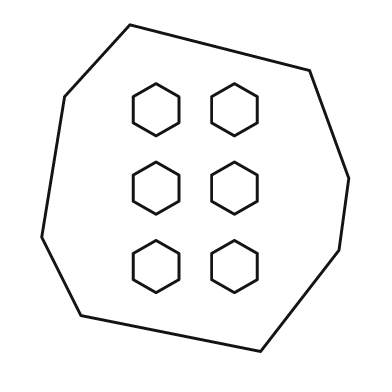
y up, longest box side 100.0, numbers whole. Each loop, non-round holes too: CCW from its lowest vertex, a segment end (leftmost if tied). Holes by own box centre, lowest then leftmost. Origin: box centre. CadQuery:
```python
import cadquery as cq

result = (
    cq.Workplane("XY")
    .moveTo(20.0, -50.0)
    .lineTo(44.0, -19.0)
    .lineTo(47.0, 3.0)
    .lineTo(35.0, 36.0)
    .lineTo(-20.0, 50.0)
    .lineTo(-40.0, 28.0)
    .lineTo(-47.0, -15.0)
    .lineTo(-35.0, -39.0)
    .close()
    .moveTo(-12.0, -32.0)
    .lineTo(-5.0, -28.0)
    .lineTo(-5.0, -20.0)
    .lineTo(-12.0, -16.0)
    .lineTo(-19.0, -20.0)
    .lineTo(-19.0, -28.0)
    .close()
    .moveTo(12.0, -32.0)
    .lineTo(19.0, -28.0)
    .lineTo(19.0, -20.0)
    .lineTo(12.0, -16.0)
    .lineTo(5.0, -20.0)
    .lineTo(5.0, -28.0)
    .close()
    .moveTo(-12.0, -8.0)
    .lineTo(-5.0, -4.0)
    .lineTo(-5.0, 4.0)
    .lineTo(-12.0, 8.0)
    .lineTo(-19.0, 4.0)
    .lineTo(-19.0, -4.0)
    .close()
    .moveTo(12.0, -8.0)
    .lineTo(19.0, -4.0)
    .lineTo(19.0, 4.0)
    .lineTo(12.0, 8.0)
    .lineTo(5.0, 4.0)
    .lineTo(5.0, -4.0)
    .close()
    .moveTo(-12.0, 16.0)
    .lineTo(-5.0, 20.0)
    .lineTo(-5.0, 28.0)
    .lineTo(-12.0, 32.0)
    .lineTo(-19.0, 28.0)
    .lineTo(-19.0, 20.0)
    .close()
    .moveTo(12.0, 16.0)
    .lineTo(19.0, 20.0)
    .lineTo(19.0, 28.0)
    .lineTo(12.0, 32.0)
    .lineTo(5.0, 28.0)
    .lineTo(5.0, 20.0)
    .close()
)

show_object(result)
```